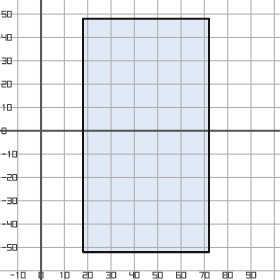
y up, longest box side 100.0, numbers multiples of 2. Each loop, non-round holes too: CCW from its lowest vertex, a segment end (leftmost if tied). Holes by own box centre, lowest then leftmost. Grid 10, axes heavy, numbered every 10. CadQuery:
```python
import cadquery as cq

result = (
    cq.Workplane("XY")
    .moveTo(18.0, -52.0)
    .lineTo(72.0, -52.0)
    .lineTo(72.0, 48.0)
    .lineTo(18.0, 48.0)
    .close()
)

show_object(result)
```